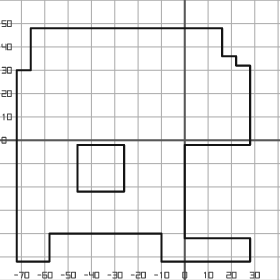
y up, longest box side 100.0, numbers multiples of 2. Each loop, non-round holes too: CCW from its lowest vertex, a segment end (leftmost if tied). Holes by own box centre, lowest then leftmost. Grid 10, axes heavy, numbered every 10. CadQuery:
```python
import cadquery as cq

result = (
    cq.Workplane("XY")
    .moveTo(-72.0, -52.0)
    .lineTo(-58.0, -52.0)
    .lineTo(-58.0, -40.0)
    .lineTo(-10.0, -40.0)
    .lineTo(-10.0, -52.0)
    .lineTo(28.0, -52.0)
    .lineTo(28.0, -42.0)
    .lineTo(0.0, -42.0)
    .lineTo(0.0, -2.0)
    .lineTo(28.0, -2.0)
    .lineTo(28.0, 32.0)
    .lineTo(22.0, 32.0)
    .lineTo(22.0, 36.0)
    .lineTo(16.0, 36.0)
    .lineTo(16.0, 48.0)
    .lineTo(-66.0, 48.0)
    .lineTo(-66.0, 30.0)
    .lineTo(-72.0, 30.0)
    .close()
    .moveTo(-46.0, -22.0)
    .lineTo(-26.0, -22.0)
    .lineTo(-26.0, -2.0)
    .lineTo(-46.0, -2.0)
    .close()
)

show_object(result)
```